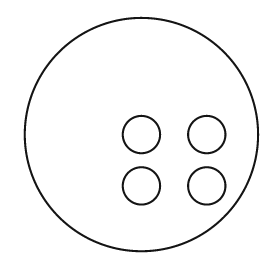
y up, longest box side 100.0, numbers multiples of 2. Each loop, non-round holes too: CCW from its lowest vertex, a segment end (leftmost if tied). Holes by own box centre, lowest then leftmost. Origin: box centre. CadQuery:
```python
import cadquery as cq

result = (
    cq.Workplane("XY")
    .moveTo(0.0, 0.0)
    .circle(50.0)
    .moveTo(0.0, -22.0)
    .circle(8.0)
    .moveTo(28.0, -22.0)
    .circle(8.0)
    .moveTo(0.0, 0.0)
    .circle(8.0)
    .moveTo(28.0, 0.0)
    .circle(8.0)
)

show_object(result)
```